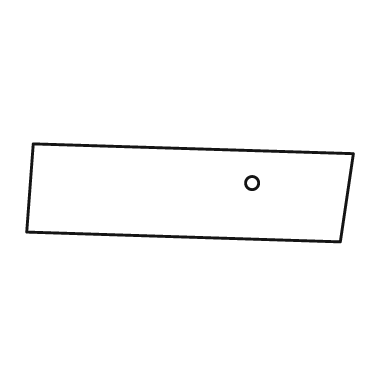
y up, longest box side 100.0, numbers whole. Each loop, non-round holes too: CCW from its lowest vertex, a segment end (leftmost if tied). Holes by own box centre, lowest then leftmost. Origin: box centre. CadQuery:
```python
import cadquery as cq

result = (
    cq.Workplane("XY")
    .moveTo(46.0, -15.0)
    .lineTo(50.0, 12.0)
    .lineTo(-48.0, 15.0)
    .lineTo(-50.0, -12.0)
    .close()
    .moveTo(19.0, 3.0)
    .circle(2.0)
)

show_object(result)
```